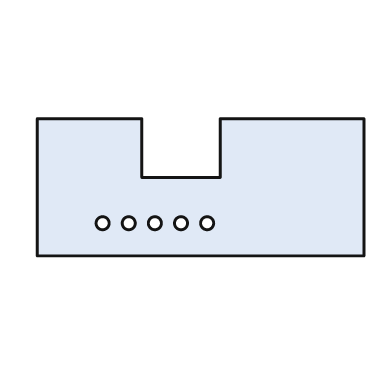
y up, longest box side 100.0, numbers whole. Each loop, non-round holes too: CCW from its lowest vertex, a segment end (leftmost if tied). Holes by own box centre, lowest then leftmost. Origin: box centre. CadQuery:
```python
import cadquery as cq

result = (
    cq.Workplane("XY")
    .moveTo(-50.0, -21.0)
    .lineTo(50.0, -21.0)
    .lineTo(50.0, 21.0)
    .lineTo(6.0, 21.0)
    .lineTo(6.0, 3.0)
    .lineTo(-18.0, 3.0)
    .lineTo(-18.0, 21.0)
    .lineTo(-50.0, 21.0)
    .close()
    .moveTo(-30.0, -11.0)
    .circle(2.0)
    .moveTo(-22.0, -11.0)
    .circle(2.0)
    .moveTo(-14.0, -11.0)
    .circle(2.0)
    .moveTo(-6.0, -11.0)
    .circle(2.0)
    .moveTo(2.0, -11.0)
    .circle(2.0)
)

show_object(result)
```